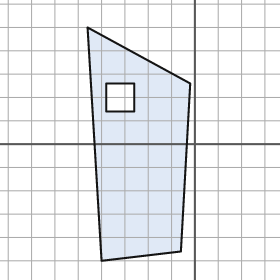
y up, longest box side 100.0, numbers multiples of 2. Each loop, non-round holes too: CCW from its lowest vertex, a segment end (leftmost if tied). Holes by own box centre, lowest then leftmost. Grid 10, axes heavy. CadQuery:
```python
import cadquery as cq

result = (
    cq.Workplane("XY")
    .moveTo(-40.0, -50.0)
    .lineTo(-6.0, -46.0)
    .lineTo(-2.0, 26.0)
    .lineTo(-46.0, 50.0)
    .close()
    .moveTo(-38.0, 14.0)
    .lineTo(-26.0, 14.0)
    .lineTo(-26.0, 26.0)
    .lineTo(-38.0, 26.0)
    .close()
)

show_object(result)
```